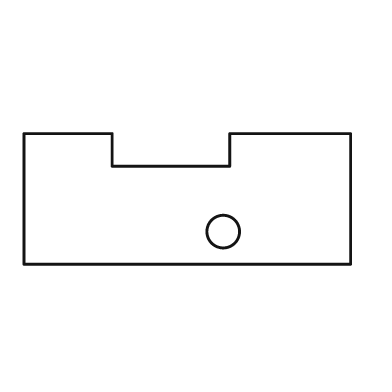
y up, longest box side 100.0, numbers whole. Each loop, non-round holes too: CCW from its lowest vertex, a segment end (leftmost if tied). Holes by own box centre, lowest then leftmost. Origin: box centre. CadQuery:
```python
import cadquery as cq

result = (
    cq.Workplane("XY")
    .moveTo(-50.0, -20.0)
    .lineTo(50.0, -20.0)
    .lineTo(50.0, 20.0)
    .lineTo(13.0, 20.0)
    .lineTo(13.0, 10.0)
    .lineTo(-23.0, 10.0)
    .lineTo(-23.0, 20.0)
    .lineTo(-50.0, 20.0)
    .close()
    .moveTo(11.0, -10.0)
    .circle(5.0)
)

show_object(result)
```